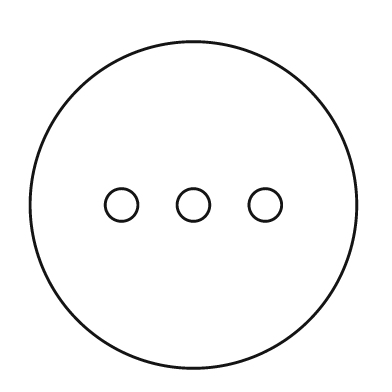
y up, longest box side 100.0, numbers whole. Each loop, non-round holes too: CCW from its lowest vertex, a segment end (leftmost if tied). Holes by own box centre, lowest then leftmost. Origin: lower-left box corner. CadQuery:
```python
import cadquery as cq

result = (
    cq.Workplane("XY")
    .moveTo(50.0, 50.0)
    .circle(50.0)
    .moveTo(28.0, 50.0)
    .circle(5.0)
    .moveTo(50.0, 50.0)
    .circle(5.0)
    .moveTo(72.0, 50.0)
    .circle(5.0)
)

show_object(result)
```